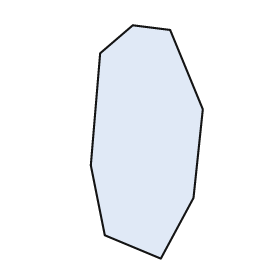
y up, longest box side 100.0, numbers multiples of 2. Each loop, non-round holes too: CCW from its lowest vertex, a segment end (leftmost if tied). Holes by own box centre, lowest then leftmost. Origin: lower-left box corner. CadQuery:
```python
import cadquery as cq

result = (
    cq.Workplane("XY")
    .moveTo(30.0, 0.0)
    .lineTo(44.0, 26.0)
    .lineTo(48.0, 64.0)
    .lineTo(34.0, 98.0)
    .lineTo(18.0, 100.0)
    .lineTo(4.0, 88.0)
    .lineTo(0.0, 40.0)
    .lineTo(6.0, 10.0)
    .close()
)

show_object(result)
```